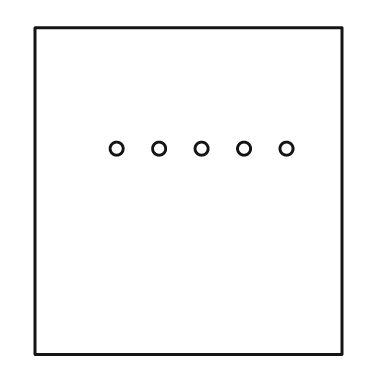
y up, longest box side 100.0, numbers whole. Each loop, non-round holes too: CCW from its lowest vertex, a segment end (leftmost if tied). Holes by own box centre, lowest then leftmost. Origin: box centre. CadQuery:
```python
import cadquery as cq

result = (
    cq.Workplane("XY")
    .moveTo(-47.0, -50.0)
    .lineTo(47.0, -50.0)
    .lineTo(47.0, 50.0)
    .lineTo(-47.0, 50.0)
    .close()
    .moveTo(-22.0, 13.0)
    .circle(2.0)
    .moveTo(-9.0, 13.0)
    .circle(2.0)
    .moveTo(4.0, 13.0)
    .circle(2.0)
    .moveTo(17.0, 13.0)
    .circle(2.0)
    .moveTo(30.0, 13.0)
    .circle(2.0)
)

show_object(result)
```